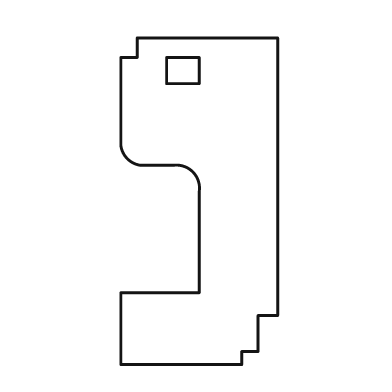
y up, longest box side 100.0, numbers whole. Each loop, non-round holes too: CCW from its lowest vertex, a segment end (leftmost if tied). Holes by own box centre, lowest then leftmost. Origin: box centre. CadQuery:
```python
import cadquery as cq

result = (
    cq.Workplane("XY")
    .moveTo(-24.0, -50.0)
    .lineTo(13.0, -50.0)
    .lineTo(13.0, -46.0)
    .lineTo(18.0, -46.0)
    .lineTo(18.0, -35.0)
    .lineTo(24.0, -35.0)
    .lineTo(24.0, 50.0)
    .lineTo(-19.0, 50.0)
    .lineTo(-19.0, 44.0)
    .lineTo(-24.0, 44.0)
    .lineTo(-24.0, 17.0)
    .threePointArc((-22.0, 13.0), (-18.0, 11.0))
    .lineTo(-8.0, 11.0)
    .threePointArc((-2.0, 9.0), (0.0, 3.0))
    .lineTo(0.0, -28.0)
    .lineTo(-24.0, -28.0)
    .close()
    .moveTo(-10.0, 36.0)
    .lineTo(0.0, 36.0)
    .lineTo(0.0, 44.0)
    .lineTo(-10.0, 44.0)
    .close()
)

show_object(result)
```